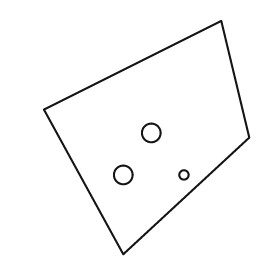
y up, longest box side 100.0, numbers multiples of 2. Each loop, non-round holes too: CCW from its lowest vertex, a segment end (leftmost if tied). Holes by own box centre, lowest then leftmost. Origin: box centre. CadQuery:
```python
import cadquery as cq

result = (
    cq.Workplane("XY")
    .moveTo(-10.0, -50.0)
    .lineTo(44.0, 0.0)
    .lineTo(32.0, 50.0)
    .lineTo(-44.0, 12.0)
    .close()
    .moveTo(-10.0, -16.0)
    .circle(4.0)
    .moveTo(16.0, -16.0)
    .circle(2.0)
    .moveTo(2.0, 2.0)
    .circle(4.0)
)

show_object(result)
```